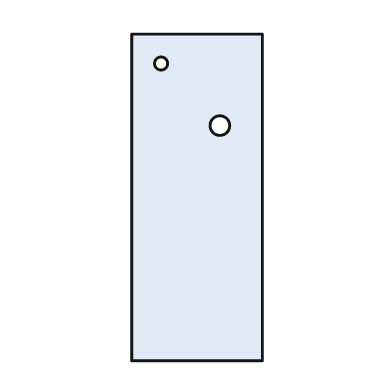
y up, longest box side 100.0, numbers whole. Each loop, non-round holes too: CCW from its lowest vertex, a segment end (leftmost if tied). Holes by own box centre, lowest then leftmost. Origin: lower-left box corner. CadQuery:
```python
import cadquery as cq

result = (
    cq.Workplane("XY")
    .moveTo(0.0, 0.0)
    .lineTo(40.0, 0.0)
    .lineTo(40.0, 100.0)
    .lineTo(0.0, 100.0)
    .close()
    .moveTo(27.0, 72.0)
    .circle(3.0)
    .moveTo(9.0, 91.0)
    .circle(2.0)
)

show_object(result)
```